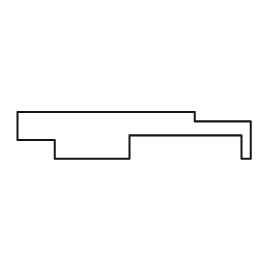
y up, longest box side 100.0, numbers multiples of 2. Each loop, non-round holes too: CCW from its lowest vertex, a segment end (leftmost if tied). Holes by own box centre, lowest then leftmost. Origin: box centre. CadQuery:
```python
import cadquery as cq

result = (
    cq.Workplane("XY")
    .moveTo(-34.0, -10.0)
    .lineTo(-2.0, -10.0)
    .lineTo(-2.0, 0.0)
    .lineTo(46.0, 0.0)
    .lineTo(46.0, -10.0)
    .lineTo(50.0, -10.0)
    .lineTo(50.0, 6.0)
    .lineTo(26.0, 6.0)
    .lineTo(26.0, 10.0)
    .lineTo(-50.0, 10.0)
    .lineTo(-50.0, -2.0)
    .lineTo(-34.0, -2.0)
    .close()
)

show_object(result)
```